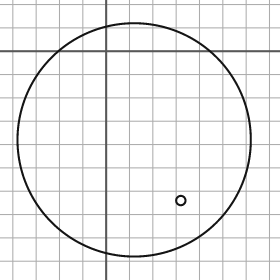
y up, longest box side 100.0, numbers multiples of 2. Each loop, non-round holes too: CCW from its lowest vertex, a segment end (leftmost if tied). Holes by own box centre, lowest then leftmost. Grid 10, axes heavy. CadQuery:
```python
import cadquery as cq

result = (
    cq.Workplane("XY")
    .moveTo(12.0, -38.0)
    .circle(50.0)
    .moveTo(32.0, -64.0)
    .circle(2.0)
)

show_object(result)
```